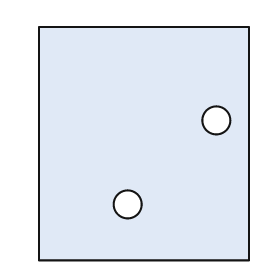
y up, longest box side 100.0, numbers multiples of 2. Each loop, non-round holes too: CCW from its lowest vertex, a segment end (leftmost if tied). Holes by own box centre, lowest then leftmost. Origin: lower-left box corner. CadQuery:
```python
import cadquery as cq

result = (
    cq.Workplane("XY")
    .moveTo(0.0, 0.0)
    .lineTo(90.0, 0.0)
    .lineTo(90.0, 100.0)
    .lineTo(0.0, 100.0)
    .close()
    .moveTo(38.0, 24.0)
    .circle(6.0)
    .moveTo(76.0, 60.0)
    .circle(6.0)
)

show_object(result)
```